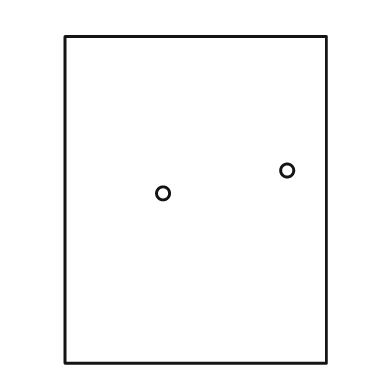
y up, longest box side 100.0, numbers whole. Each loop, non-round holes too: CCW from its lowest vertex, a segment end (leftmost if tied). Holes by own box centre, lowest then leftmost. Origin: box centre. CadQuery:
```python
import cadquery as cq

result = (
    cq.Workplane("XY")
    .moveTo(-40.0, -50.0)
    .lineTo(40.0, -50.0)
    .lineTo(40.0, 50.0)
    .lineTo(-40.0, 50.0)
    .close()
    .moveTo(-10.0, 2.0)
    .circle(2.0)
    .moveTo(28.0, 9.0)
    .circle(2.0)
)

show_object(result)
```